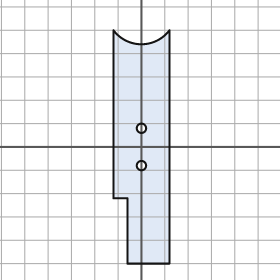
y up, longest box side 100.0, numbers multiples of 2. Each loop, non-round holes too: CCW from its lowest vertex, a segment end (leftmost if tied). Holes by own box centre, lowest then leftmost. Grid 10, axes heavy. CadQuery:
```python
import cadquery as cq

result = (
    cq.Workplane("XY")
    .moveTo(-6.0, -50.0)
    .lineTo(12.0, -50.0)
    .lineTo(12.0, 50.0)
    .threePointArc((0.0, 44.0), (-12.0, 50.0))
    .lineTo(-12.0, -22.0)
    .lineTo(-6.0, -22.0)
    .close()
    .moveTo(0.0, -8.0)
    .circle(2.0)
    .moveTo(0.0, 8.0)
    .circle(2.0)
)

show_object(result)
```